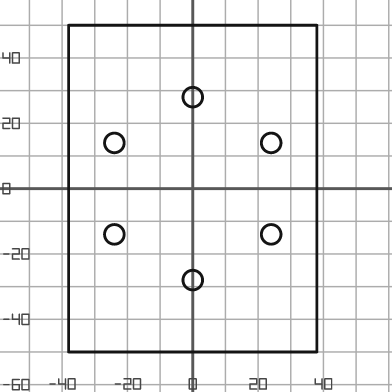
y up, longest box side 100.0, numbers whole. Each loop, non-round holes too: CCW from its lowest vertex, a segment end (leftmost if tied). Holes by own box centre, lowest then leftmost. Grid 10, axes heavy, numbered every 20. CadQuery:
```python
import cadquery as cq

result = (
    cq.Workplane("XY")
    .moveTo(-38.0, -50.0)
    .lineTo(38.0, -50.0)
    .lineTo(38.0, 50.0)
    .lineTo(-38.0, 50.0)
    .close()
    .moveTo(0.0, -28.0)
    .circle(3.0)
    .moveTo(-24.0, -14.0)
    .circle(3.0)
    .moveTo(24.0, -14.0)
    .circle(3.0)
    .moveTo(-24.0, 14.0)
    .circle(3.0)
    .moveTo(24.0, 14.0)
    .circle(3.0)
    .moveTo(0.0, 28.0)
    .circle(3.0)
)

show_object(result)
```